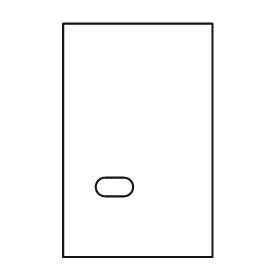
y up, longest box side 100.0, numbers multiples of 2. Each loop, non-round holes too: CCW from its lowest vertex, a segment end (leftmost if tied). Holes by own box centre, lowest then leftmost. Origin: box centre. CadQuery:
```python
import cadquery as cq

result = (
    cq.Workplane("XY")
    .moveTo(-32.0, -50.0)
    .lineTo(32.0, -50.0)
    .lineTo(32.0, 50.0)
    .lineTo(-32.0, 50.0)
    .close()
    .moveTo(-14.0, -24.0)
    .lineTo(-6.0, -24.0)
    .threePointArc((-2.0, -20.0), (-6.0, -16.0))
    .lineTo(-14.0, -16.0)
    .threePointArc((-18.0, -20.0), (-14.0, -24.0))
    .close()
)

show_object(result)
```